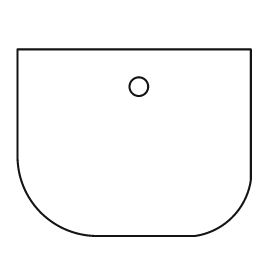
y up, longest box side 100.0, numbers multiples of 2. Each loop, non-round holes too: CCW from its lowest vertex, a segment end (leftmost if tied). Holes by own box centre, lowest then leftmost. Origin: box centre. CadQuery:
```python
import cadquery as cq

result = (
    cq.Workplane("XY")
    .moveTo(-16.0, -40.0)
    .lineTo(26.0, -40.0)
    .threePointArc((42.0, -32.0), (50.0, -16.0))
    .lineTo(50.0, 40.0)
    .lineTo(-50.0, 40.0)
    .lineTo(-50.0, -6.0)
    .threePointArc((-40.0, -30.0), (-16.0, -40.0))
    .close()
    .moveTo(2.0, 24.0)
    .circle(4.0)
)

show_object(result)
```